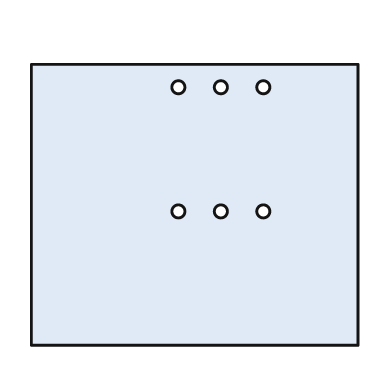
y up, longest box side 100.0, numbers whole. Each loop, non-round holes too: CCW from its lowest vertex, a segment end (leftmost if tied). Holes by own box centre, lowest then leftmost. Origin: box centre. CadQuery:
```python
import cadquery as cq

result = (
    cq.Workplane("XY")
    .moveTo(-50.0, -43.0)
    .lineTo(50.0, -43.0)
    .lineTo(50.0, 43.0)
    .lineTo(-50.0, 43.0)
    .close()
    .moveTo(-5.0, -2.0)
    .circle(2.0)
    .moveTo(8.0, -2.0)
    .circle(2.0)
    .moveTo(21.0, -2.0)
    .circle(2.0)
    .moveTo(-5.0, 36.0)
    .circle(2.0)
    .moveTo(8.0, 36.0)
    .circle(2.0)
    .moveTo(21.0, 36.0)
    .circle(2.0)
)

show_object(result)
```